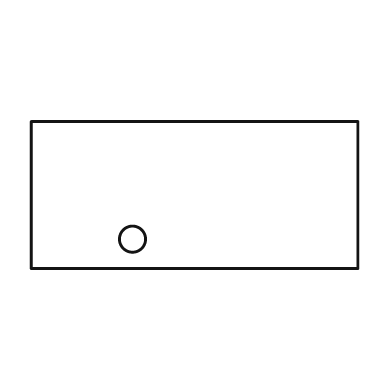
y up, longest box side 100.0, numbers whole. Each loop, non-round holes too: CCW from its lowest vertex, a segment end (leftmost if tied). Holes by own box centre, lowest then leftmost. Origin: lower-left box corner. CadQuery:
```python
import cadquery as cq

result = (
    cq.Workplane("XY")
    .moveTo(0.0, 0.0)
    .lineTo(100.0, 0.0)
    .lineTo(100.0, 45.0)
    .lineTo(0.0, 45.0)
    .close()
    .moveTo(31.0, 9.0)
    .circle(4.0)
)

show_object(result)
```